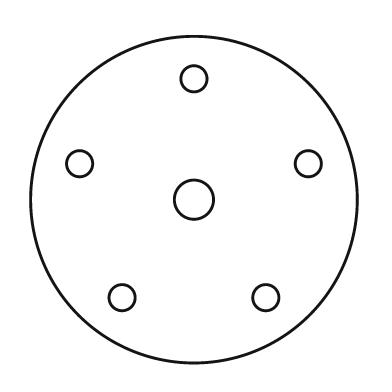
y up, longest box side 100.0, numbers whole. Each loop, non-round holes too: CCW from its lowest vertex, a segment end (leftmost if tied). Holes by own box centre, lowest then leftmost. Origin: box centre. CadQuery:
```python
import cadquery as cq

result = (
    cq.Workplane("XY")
    .moveTo(0.0, 0.0)
    .circle(50.0)
    .moveTo(-22.0, -30.0)
    .circle(4.0)
    .moveTo(22.0, -30.0)
    .circle(4.0)
    .moveTo(0.0, 0.0)
    .circle(6.0)
    .moveTo(-35.0, 11.0)
    .circle(4.0)
    .moveTo(35.0, 11.0)
    .circle(4.0)
    .moveTo(0.0, 37.0)
    .circle(4.0)
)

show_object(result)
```